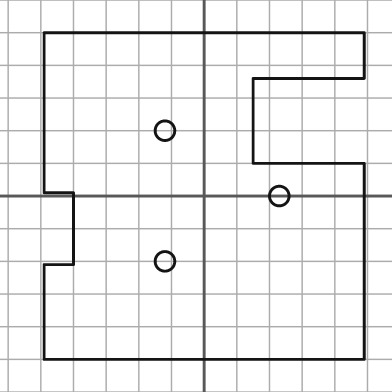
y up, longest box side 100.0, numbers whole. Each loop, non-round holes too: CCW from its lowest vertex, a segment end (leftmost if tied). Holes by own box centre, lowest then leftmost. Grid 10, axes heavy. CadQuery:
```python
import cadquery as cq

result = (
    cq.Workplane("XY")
    .moveTo(-49.0, -50.0)
    .lineTo(49.0, -50.0)
    .lineTo(49.0, 10.0)
    .lineTo(15.0, 10.0)
    .lineTo(15.0, 36.0)
    .lineTo(49.0, 36.0)
    .lineTo(49.0, 50.0)
    .lineTo(-49.0, 50.0)
    .lineTo(-49.0, 1.0)
    .lineTo(-40.0, 1.0)
    .lineTo(-40.0, -21.0)
    .lineTo(-49.0, -21.0)
    .close()
    .moveTo(-12.0, -20.0)
    .circle(3.0)
    .moveTo(23.0, 0.0)
    .circle(3.0)
    .moveTo(-12.0, 20.0)
    .circle(3.0)
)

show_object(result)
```